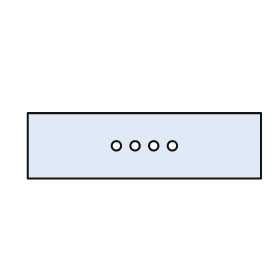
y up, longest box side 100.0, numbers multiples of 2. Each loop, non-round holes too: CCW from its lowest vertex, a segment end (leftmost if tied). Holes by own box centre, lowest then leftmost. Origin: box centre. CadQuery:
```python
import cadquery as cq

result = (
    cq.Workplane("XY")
    .moveTo(-50.0, -14.0)
    .lineTo(50.0, -14.0)
    .lineTo(50.0, 14.0)
    .lineTo(-50.0, 14.0)
    .close()
    .moveTo(-12.0, 0.0)
    .circle(2.0)
    .moveTo(-4.0, 0.0)
    .circle(2.0)
    .moveTo(4.0, 0.0)
    .circle(2.0)
    .moveTo(12.0, 0.0)
    .circle(2.0)
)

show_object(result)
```